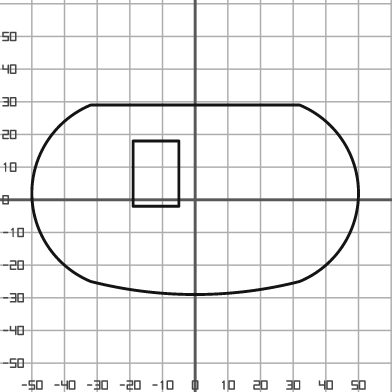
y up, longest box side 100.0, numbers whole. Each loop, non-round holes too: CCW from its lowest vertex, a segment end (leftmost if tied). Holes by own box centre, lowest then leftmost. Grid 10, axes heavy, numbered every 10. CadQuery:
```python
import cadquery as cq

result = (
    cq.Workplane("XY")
    .moveTo(-32.0, -25.0)
    .threePointArc((0.0, -29.0), (32.0, -25.0))
    .threePointArc((50.0, 2.0), (32.0, 29.0))
    .lineTo(-32.0, 29.0)
    .threePointArc((-50.0, 2.0), (-32.0, -25.0))
    .close()
    .moveTo(-19.0, -2.0)
    .lineTo(-5.0, -2.0)
    .lineTo(-5.0, 18.0)
    .lineTo(-19.0, 18.0)
    .close()
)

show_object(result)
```